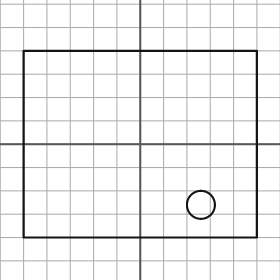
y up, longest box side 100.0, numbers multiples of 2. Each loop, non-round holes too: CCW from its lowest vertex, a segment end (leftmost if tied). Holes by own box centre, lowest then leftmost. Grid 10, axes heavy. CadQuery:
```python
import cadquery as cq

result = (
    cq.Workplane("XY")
    .moveTo(-50.0, -40.0)
    .lineTo(50.0, -40.0)
    .lineTo(50.0, 40.0)
    .lineTo(-50.0, 40.0)
    .close()
    .moveTo(26.0, -26.0)
    .circle(6.0)
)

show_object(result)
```